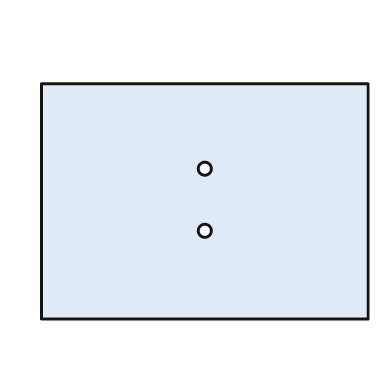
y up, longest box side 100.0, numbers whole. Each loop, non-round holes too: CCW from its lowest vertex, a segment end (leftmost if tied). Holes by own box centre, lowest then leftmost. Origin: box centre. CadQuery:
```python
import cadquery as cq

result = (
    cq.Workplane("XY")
    .moveTo(-50.0, -36.0)
    .lineTo(50.0, -36.0)
    .lineTo(50.0, 36.0)
    .lineTo(-50.0, 36.0)
    .close()
    .moveTo(0.0, -9.0)
    .circle(2.0)
    .moveTo(0.0, 10.0)
    .circle(2.0)
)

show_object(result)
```